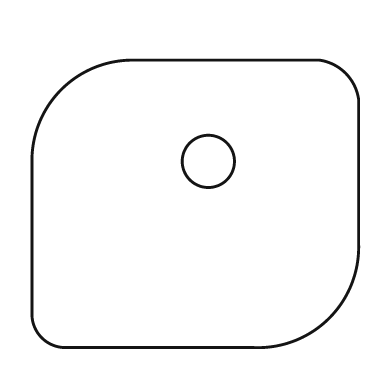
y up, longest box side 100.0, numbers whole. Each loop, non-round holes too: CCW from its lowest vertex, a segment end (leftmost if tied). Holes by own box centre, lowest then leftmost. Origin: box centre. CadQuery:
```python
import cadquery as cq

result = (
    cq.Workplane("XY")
    .moveTo(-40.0, -44.0)
    .lineTo(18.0, -44.0)
    .threePointArc((41.0, -35.0), (50.0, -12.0))
    .lineTo(50.0, 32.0)
    .threePointArc((46.0, 40.0), (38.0, 44.0))
    .lineTo(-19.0, 44.0)
    .threePointArc((-41.0, 35.0), (-50.0, 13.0))
    .lineTo(-50.0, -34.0)
    .threePointArc((-47.0, -41.0), (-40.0, -44.0))
    .close()
    .moveTo(4.0, 13.0)
    .circle(8.0)
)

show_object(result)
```